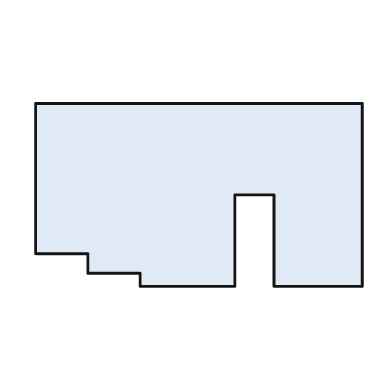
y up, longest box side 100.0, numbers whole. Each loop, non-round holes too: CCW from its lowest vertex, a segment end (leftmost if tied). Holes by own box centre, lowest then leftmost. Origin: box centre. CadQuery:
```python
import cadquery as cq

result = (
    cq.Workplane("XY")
    .moveTo(-18.0, -28.0)
    .lineTo(11.0, -28.0)
    .lineTo(11.0, 0.0)
    .lineTo(23.0, 0.0)
    .lineTo(23.0, -28.0)
    .lineTo(50.0, -28.0)
    .lineTo(50.0, 28.0)
    .lineTo(-50.0, 28.0)
    .lineTo(-50.0, -18.0)
    .lineTo(-34.0, -18.0)
    .lineTo(-34.0, -24.0)
    .lineTo(-18.0, -24.0)
    .close()
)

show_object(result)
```